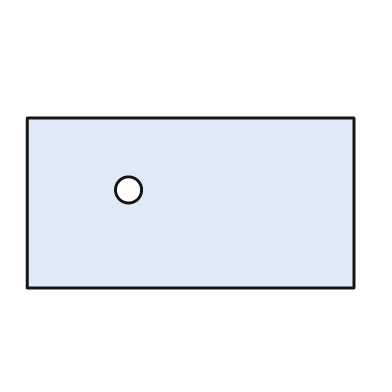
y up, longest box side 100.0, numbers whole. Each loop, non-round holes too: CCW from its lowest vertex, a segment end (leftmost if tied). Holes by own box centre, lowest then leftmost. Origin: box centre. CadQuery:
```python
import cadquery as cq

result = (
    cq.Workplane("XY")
    .moveTo(-50.0, -26.0)
    .lineTo(50.0, -26.0)
    .lineTo(50.0, 26.0)
    .lineTo(-50.0, 26.0)
    .close()
    .moveTo(-19.0, 4.0)
    .circle(4.0)
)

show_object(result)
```